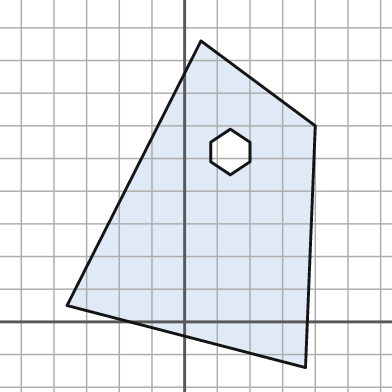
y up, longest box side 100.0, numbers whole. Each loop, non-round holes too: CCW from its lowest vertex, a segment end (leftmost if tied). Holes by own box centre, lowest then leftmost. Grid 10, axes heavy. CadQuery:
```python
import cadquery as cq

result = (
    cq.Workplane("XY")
    .moveTo(37.0, -14.0)
    .lineTo(40.0, 60.0)
    .lineTo(5.0, 86.0)
    .lineTo(-36.0, 5.0)
    .close()
    .moveTo(14.0, 45.0)
    .lineTo(20.0, 49.0)
    .lineTo(20.0, 55.0)
    .lineTo(14.0, 59.0)
    .lineTo(8.0, 55.0)
    .lineTo(8.0, 49.0)
    .close()
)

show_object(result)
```